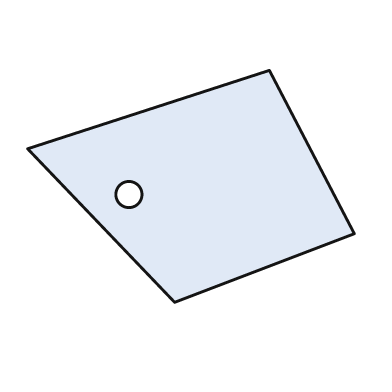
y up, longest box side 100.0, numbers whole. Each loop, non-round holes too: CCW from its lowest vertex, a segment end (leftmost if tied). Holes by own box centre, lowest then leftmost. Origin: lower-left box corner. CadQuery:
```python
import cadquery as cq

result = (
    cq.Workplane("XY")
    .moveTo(45.0, 0.0)
    .lineTo(100.0, 21.0)
    .lineTo(74.0, 71.0)
    .lineTo(0.0, 47.0)
    .close()
    .moveTo(31.0, 33.0)
    .circle(4.0)
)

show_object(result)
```